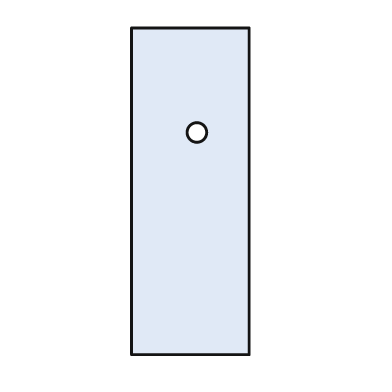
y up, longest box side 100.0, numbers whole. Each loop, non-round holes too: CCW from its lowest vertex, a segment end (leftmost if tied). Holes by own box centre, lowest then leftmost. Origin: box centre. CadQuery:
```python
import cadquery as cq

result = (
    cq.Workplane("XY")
    .moveTo(-18.0, -50.0)
    .lineTo(18.0, -50.0)
    .lineTo(18.0, 50.0)
    .lineTo(-18.0, 50.0)
    .close()
    .moveTo(2.0, 18.0)
    .circle(3.0)
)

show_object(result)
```